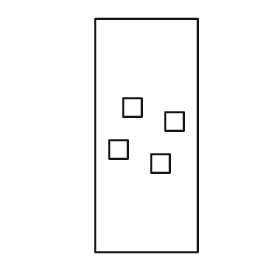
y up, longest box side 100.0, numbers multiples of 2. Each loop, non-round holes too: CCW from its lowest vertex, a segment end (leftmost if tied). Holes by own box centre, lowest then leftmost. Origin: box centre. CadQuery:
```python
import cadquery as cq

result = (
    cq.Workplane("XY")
    .moveTo(-22.0, -50.0)
    .lineTo(22.0, -50.0)
    .lineTo(22.0, 50.0)
    .lineTo(-22.0, 50.0)
    .close()
    .moveTo(2.0, -16.0)
    .lineTo(10.0, -16.0)
    .lineTo(10.0, -8.0)
    .lineTo(2.0, -8.0)
    .close()
    .moveTo(-16.0, -10.0)
    .lineTo(-8.0, -10.0)
    .lineTo(-8.0, -2.0)
    .lineTo(-16.0, -2.0)
    .close()
    .moveTo(8.0, 2.0)
    .lineTo(16.0, 2.0)
    .lineTo(16.0, 10.0)
    .lineTo(8.0, 10.0)
    .close()
    .moveTo(-10.0, 8.0)
    .lineTo(-2.0, 8.0)
    .lineTo(-2.0, 16.0)
    .lineTo(-10.0, 16.0)
    .close()
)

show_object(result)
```